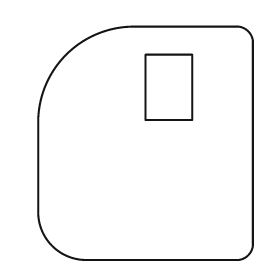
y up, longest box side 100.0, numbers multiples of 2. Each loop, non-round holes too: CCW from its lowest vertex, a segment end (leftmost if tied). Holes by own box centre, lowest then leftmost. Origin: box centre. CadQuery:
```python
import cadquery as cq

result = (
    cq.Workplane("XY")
    .moveTo(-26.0, -50.0)
    .lineTo(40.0, -50.0)
    .threePointArc((44.0, -48.0), (46.0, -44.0))
    .lineTo(46.0, 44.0)
    .threePointArc((44.0, 48.0), (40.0, 50.0))
    .lineTo(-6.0, 50.0)
    .threePointArc((-34.0, 38.0), (-46.0, 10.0))
    .lineTo(-46.0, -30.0)
    .threePointArc((-40.0, -44.0), (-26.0, -50.0))
    .close()
    .moveTo(0.0, 10.0)
    .lineTo(20.0, 10.0)
    .lineTo(20.0, 38.0)
    .lineTo(0.0, 38.0)
    .close()
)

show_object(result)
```